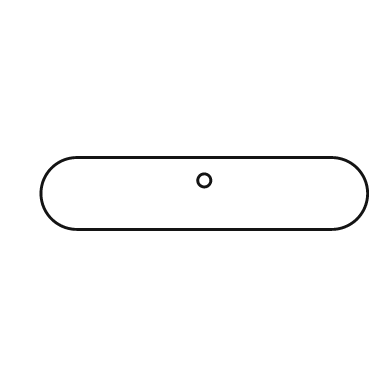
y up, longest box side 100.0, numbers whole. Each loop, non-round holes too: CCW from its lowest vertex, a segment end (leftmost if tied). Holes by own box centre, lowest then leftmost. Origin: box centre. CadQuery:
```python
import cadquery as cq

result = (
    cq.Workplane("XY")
    .moveTo(-39.0, -11.0)
    .lineTo(39.0, -11.0)
    .threePointArc((50.0, 0.0), (39.0, 11.0))
    .lineTo(-39.0, 11.0)
    .threePointArc((-50.0, 0.0), (-39.0, -11.0))
    .close()
    .moveTo(0.0, 4.0)
    .circle(2.0)
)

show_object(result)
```